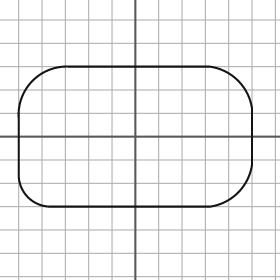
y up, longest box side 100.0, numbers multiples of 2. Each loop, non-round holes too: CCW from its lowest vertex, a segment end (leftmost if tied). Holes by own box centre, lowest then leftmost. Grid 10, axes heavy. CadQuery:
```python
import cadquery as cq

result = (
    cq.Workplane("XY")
    .moveTo(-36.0, -30.0)
    .lineTo(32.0, -30.0)
    .threePointArc((44.0, -24.0), (50.0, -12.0))
    .lineTo(50.0, 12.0)
    .threePointArc((44.0, 24.0), (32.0, 30.0))
    .lineTo(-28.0, 30.0)
    .threePointArc((-44.0, 24.0), (-50.0, 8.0))
    .lineTo(-50.0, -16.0)
    .threePointArc((-46.0, -26.0), (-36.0, -30.0))
    .close()
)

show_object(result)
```